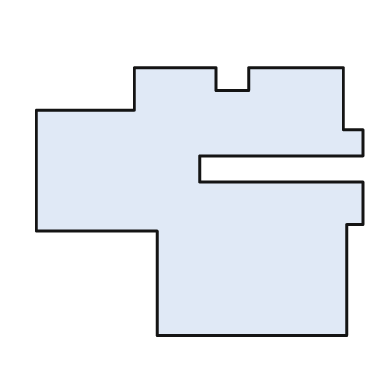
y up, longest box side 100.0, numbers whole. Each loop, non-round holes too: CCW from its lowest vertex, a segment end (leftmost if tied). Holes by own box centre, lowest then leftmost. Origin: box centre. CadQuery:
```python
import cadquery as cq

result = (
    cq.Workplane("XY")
    .moveTo(-13.0, -41.0)
    .lineTo(45.0, -41.0)
    .lineTo(45.0, -7.0)
    .lineTo(50.0, -7.0)
    .lineTo(50.0, 6.0)
    .lineTo(0.0, 6.0)
    .lineTo(0.0, 14.0)
    .lineTo(50.0, 14.0)
    .lineTo(50.0, 22.0)
    .lineTo(44.0, 22.0)
    .lineTo(44.0, 41.0)
    .lineTo(15.0, 41.0)
    .lineTo(15.0, 34.0)
    .lineTo(5.0, 34.0)
    .lineTo(5.0, 41.0)
    .lineTo(-20.0, 41.0)
    .lineTo(-20.0, 28.0)
    .lineTo(-50.0, 28.0)
    .lineTo(-50.0, -9.0)
    .lineTo(-13.0, -9.0)
    .close()
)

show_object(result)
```